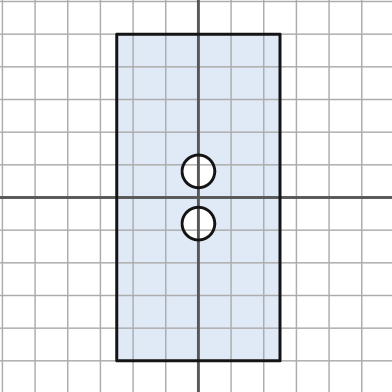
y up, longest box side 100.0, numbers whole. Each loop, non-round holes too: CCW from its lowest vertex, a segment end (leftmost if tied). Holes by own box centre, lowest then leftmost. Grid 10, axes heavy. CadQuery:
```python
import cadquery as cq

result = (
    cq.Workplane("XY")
    .moveTo(-25.0, -50.0)
    .lineTo(25.0, -50.0)
    .lineTo(25.0, 50.0)
    .lineTo(-25.0, 50.0)
    .close()
    .moveTo(0.0, -8.0)
    .circle(5.0)
    .moveTo(0.0, 8.0)
    .circle(5.0)
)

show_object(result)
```